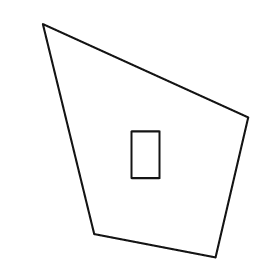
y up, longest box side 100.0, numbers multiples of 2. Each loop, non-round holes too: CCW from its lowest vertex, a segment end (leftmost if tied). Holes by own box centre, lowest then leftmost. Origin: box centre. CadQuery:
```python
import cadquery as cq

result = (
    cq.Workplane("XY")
    .moveTo(30.0, -50.0)
    .lineTo(44.0, 10.0)
    .lineTo(-44.0, 50.0)
    .lineTo(-22.0, -40.0)
    .close()
    .moveTo(-6.0, -16.0)
    .lineTo(6.0, -16.0)
    .lineTo(6.0, 4.0)
    .lineTo(-6.0, 4.0)
    .close()
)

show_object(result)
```